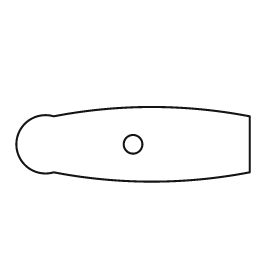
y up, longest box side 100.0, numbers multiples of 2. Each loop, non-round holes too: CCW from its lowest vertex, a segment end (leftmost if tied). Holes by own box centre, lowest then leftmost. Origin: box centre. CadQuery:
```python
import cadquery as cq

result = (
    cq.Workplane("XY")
    .moveTo(-34.0, -12.0)
    .threePointArc((8.0, -16.0), (50.0, -12.0))
    .lineTo(50.0, 12.0)
    .threePointArc((8.0, 16.0), (-34.0, 12.0))
    .threePointArc((-50.0, 0.0), (-34.0, -12.0))
    .close()
    .moveTo(0.0, 0.0)
    .circle(4.0)
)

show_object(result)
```